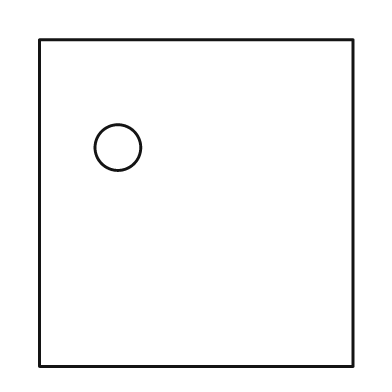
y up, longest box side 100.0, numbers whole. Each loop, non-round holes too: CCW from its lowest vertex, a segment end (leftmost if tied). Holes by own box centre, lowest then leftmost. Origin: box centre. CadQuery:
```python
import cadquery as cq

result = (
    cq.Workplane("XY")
    .moveTo(-48.0, -50.0)
    .lineTo(48.0, -50.0)
    .lineTo(48.0, 50.0)
    .lineTo(-48.0, 50.0)
    .close()
    .moveTo(-24.0, 17.0)
    .circle(7.0)
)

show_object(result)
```